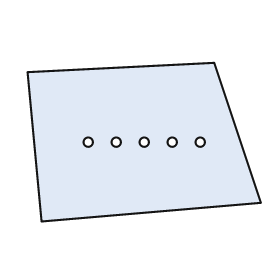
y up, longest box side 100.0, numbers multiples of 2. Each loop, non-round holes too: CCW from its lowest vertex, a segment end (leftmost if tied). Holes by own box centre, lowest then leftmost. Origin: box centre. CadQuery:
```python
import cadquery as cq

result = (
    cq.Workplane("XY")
    .moveTo(-44.0, -34.0)
    .lineTo(50.0, -26.0)
    .lineTo(30.0, 34.0)
    .lineTo(-50.0, 30.0)
    .close()
    .moveTo(-24.0, 0.0)
    .circle(2.0)
    .moveTo(-12.0, 0.0)
    .circle(2.0)
    .moveTo(0.0, 0.0)
    .circle(2.0)
    .moveTo(12.0, 0.0)
    .circle(2.0)
    .moveTo(24.0, 0.0)
    .circle(2.0)
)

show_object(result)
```